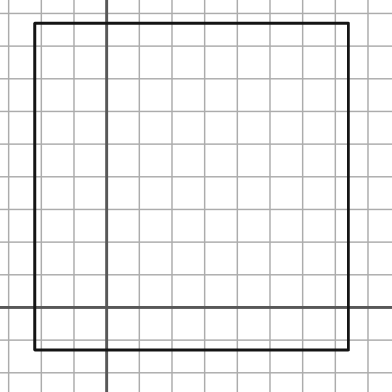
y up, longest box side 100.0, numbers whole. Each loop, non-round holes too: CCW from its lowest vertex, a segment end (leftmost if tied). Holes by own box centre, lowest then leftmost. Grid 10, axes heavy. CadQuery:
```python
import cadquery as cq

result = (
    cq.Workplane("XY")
    .moveTo(-22.0, -13.0)
    .lineTo(74.0, -13.0)
    .lineTo(74.0, 87.0)
    .lineTo(-22.0, 87.0)
    .close()
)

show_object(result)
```